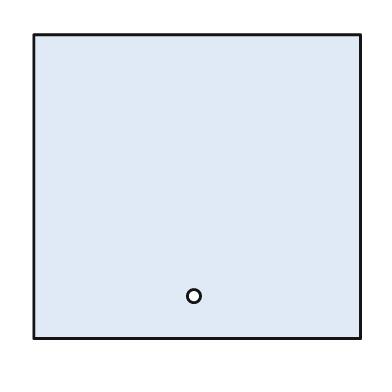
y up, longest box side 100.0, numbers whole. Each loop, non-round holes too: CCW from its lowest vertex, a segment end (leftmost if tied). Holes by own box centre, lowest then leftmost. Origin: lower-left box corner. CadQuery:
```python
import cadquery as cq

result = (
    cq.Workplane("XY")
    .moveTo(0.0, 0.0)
    .lineTo(100.0, 0.0)
    .lineTo(100.0, 93.0)
    .lineTo(0.0, 93.0)
    .close()
    .moveTo(49.0, 13.0)
    .circle(2.0)
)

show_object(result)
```